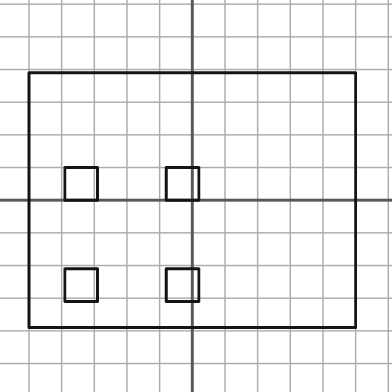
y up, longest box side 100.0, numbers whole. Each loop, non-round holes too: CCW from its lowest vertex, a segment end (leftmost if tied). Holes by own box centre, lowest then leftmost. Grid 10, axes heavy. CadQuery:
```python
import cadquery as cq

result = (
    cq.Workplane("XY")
    .moveTo(-50.0, -39.0)
    .lineTo(50.0, -39.0)
    .lineTo(50.0, 39.0)
    .lineTo(-50.0, 39.0)
    .close()
    .moveTo(-39.0, -31.0)
    .lineTo(-29.0, -31.0)
    .lineTo(-29.0, -21.0)
    .lineTo(-39.0, -21.0)
    .close()
    .moveTo(-8.0, -31.0)
    .lineTo(2.0, -31.0)
    .lineTo(2.0, -21.0)
    .lineTo(-8.0, -21.0)
    .close()
    .moveTo(-39.0, 0.0)
    .lineTo(-29.0, 0.0)
    .lineTo(-29.0, 10.0)
    .lineTo(-39.0, 10.0)
    .close()
    .moveTo(-8.0, 0.0)
    .lineTo(2.0, 0.0)
    .lineTo(2.0, 10.0)
    .lineTo(-8.0, 10.0)
    .close()
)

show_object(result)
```